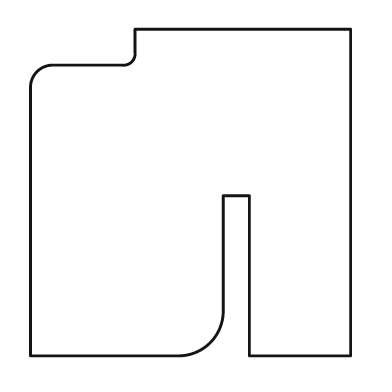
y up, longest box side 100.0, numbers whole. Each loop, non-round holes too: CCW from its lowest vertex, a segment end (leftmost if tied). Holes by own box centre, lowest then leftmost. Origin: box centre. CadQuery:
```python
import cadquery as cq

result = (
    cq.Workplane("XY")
    .moveTo(-49.0, -50.0)
    .lineTo(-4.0, -50.0)
    .threePointArc((6.0, -46.0), (10.0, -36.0))
    .lineTo(10.0, -1.0)
    .lineTo(18.0, -1.0)
    .lineTo(18.0, -50.0)
    .lineTo(49.0, -50.0)
    .lineTo(49.0, 50.0)
    .lineTo(-17.0, 50.0)
    .lineTo(-17.0, 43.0)
    .threePointArc((-18.0, 40.0), (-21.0, 39.0))
    .lineTo(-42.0, 39.0)
    .threePointArc((-47.0, 37.0), (-49.0, 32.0))
    .close()
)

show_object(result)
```